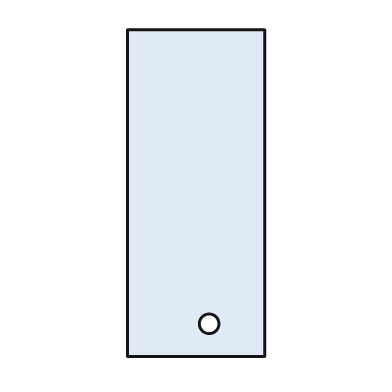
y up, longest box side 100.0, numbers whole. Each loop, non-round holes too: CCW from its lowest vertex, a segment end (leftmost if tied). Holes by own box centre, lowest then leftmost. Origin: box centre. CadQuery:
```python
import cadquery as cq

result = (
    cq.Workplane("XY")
    .moveTo(-21.0, -50.0)
    .lineTo(21.0, -50.0)
    .lineTo(21.0, 50.0)
    .lineTo(-21.0, 50.0)
    .close()
    .moveTo(4.0, -40.0)
    .circle(3.0)
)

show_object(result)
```